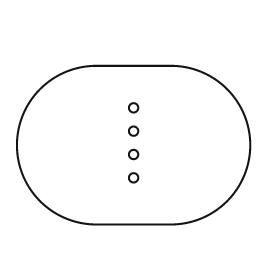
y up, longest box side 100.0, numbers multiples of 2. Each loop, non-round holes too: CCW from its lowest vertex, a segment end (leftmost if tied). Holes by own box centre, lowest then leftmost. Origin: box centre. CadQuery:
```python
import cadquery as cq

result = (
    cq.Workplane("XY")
    .moveTo(-16.0, -34.0)
    .lineTo(16.0, -34.0)
    .threePointArc((50.0, 0.0), (16.0, 34.0))
    .lineTo(-16.0, 34.0)
    .threePointArc((-50.0, 0.0), (-16.0, -34.0))
    .close()
    .moveTo(0.0, -14.0)
    .circle(2.0)
    .moveTo(0.0, -4.0)
    .circle(2.0)
    .moveTo(0.0, 6.0)
    .circle(2.0)
    .moveTo(0.0, 16.0)
    .circle(2.0)
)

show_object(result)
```